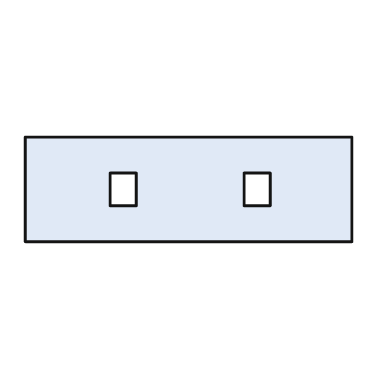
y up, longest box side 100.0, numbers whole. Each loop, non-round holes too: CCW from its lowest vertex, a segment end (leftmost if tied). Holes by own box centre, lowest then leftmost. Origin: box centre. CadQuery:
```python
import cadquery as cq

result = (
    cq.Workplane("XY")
    .moveTo(-50.0, -16.0)
    .lineTo(50.0, -16.0)
    .lineTo(50.0, 16.0)
    .lineTo(-50.0, 16.0)
    .close()
    .moveTo(-24.0, -5.0)
    .lineTo(-16.0, -5.0)
    .lineTo(-16.0, 5.0)
    .lineTo(-24.0, 5.0)
    .close()
    .moveTo(17.0, -5.0)
    .lineTo(25.0, -5.0)
    .lineTo(25.0, 5.0)
    .lineTo(17.0, 5.0)
    .close()
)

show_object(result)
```